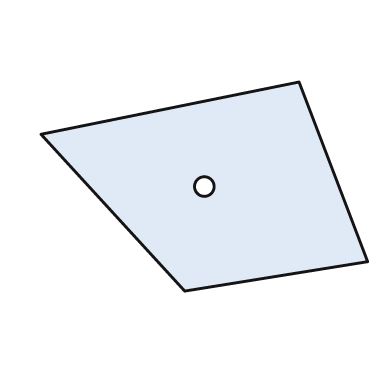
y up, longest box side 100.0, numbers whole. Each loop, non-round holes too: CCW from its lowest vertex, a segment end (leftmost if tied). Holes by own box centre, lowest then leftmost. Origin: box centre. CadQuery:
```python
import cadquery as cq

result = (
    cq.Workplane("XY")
    .moveTo(-6.0, -32.0)
    .lineTo(50.0, -23.0)
    .lineTo(29.0, 32.0)
    .lineTo(-50.0, 16.0)
    .close()
    .moveTo(0.0, 0.0)
    .circle(3.0)
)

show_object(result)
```